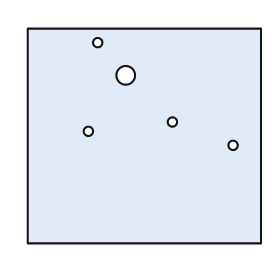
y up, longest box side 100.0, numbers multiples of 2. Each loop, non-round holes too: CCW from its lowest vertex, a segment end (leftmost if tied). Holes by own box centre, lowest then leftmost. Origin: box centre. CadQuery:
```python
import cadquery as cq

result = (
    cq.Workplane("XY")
    .moveTo(-50.0, -46.0)
    .lineTo(50.0, -46.0)
    .lineTo(50.0, 46.0)
    .lineTo(-50.0, 46.0)
    .close()
    .moveTo(38.0, -4.0)
    .circle(2.0)
    .moveTo(-24.0, 2.0)
    .circle(2.0)
    .moveTo(12.0, 6.0)
    .circle(2.0)
    .moveTo(-8.0, 26.0)
    .circle(4.0)
    .moveTo(-20.0, 40.0)
    .circle(2.0)
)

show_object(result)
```